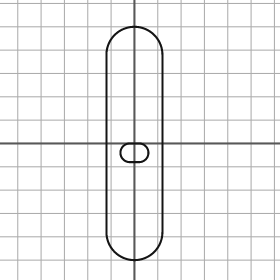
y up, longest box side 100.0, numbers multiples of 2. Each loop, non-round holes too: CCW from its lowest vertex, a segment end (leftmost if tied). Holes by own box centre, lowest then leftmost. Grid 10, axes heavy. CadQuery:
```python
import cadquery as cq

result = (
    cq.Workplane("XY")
    .moveTo(-12.0, -38.0)
    .threePointArc((0.0, -50.0), (12.0, -38.0))
    .lineTo(12.0, 38.0)
    .threePointArc((0.0, 50.0), (-12.0, 38.0))
    .close()
    .moveTo(-2.0, -8.0)
    .lineTo(2.0, -8.0)
    .threePointArc((6.0, -4.0), (2.0, 0.0))
    .lineTo(-2.0, 0.0)
    .threePointArc((-6.0, -4.0), (-2.0, -8.0))
    .close()
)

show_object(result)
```